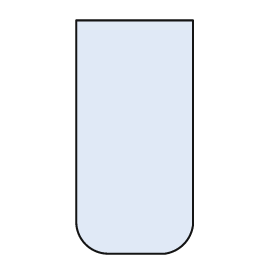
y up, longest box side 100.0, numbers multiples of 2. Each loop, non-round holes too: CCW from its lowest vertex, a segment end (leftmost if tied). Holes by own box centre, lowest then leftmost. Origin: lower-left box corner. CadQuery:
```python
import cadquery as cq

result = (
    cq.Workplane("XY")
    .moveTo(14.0, 0.0)
    .lineTo(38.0, 0.0)
    .threePointArc((46.0, 4.0), (50.0, 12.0))
    .lineTo(50.0, 100.0)
    .lineTo(0.0, 100.0)
    .lineTo(0.0, 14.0)
    .threePointArc((4.0, 4.0), (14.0, 0.0))
    .close()
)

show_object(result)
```